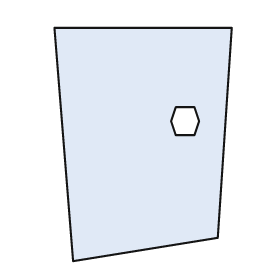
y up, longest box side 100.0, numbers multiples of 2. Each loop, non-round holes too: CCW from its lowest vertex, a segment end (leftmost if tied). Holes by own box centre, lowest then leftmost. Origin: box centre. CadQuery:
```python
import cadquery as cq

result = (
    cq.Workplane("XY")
    .moveTo(-30.0, -50.0)
    .lineTo(32.0, -40.0)
    .lineTo(38.0, 50.0)
    .lineTo(-38.0, 50.0)
    .close()
    .moveTo(14.0, 4.0)
    .lineTo(22.0, 4.0)
    .lineTo(24.0, 10.0)
    .lineTo(22.0, 16.0)
    .lineTo(14.0, 16.0)
    .lineTo(12.0, 10.0)
    .close()
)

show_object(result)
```